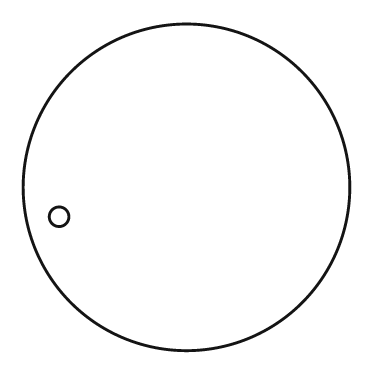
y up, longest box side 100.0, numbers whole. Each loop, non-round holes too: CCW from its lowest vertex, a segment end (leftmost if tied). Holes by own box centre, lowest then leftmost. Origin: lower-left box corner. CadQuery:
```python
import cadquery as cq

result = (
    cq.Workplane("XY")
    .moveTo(50.0, 50.0)
    .circle(50.0)
    .moveTo(11.0, 41.0)
    .circle(3.0)
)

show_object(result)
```